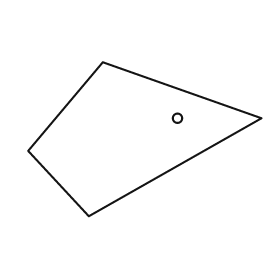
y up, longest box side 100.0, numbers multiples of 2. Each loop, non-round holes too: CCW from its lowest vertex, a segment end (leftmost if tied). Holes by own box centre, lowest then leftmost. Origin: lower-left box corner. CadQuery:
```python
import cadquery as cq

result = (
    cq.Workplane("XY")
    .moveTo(26.0, 0.0)
    .lineTo(100.0, 42.0)
    .lineTo(32.0, 66.0)
    .lineTo(0.0, 28.0)
    .close()
    .moveTo(64.0, 42.0)
    .circle(2.0)
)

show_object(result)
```